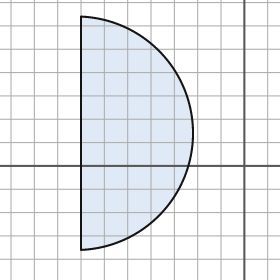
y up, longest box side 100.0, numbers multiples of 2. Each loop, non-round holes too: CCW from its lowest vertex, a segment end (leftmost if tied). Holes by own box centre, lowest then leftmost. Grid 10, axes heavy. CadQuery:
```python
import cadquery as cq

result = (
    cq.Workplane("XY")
    .moveTo(-70.0, -36.0)
    .threePointArc((-22.0, 14.0), (-70.0, 64.0))
    .close()
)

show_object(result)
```